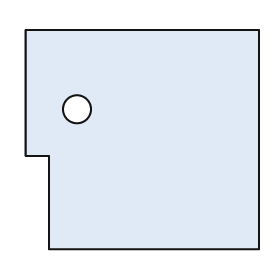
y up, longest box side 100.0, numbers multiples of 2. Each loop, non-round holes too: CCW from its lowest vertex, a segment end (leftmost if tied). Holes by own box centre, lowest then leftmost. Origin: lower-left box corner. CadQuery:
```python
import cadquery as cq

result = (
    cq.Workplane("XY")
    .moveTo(10.0, 0.0)
    .lineTo(100.0, 0.0)
    .lineTo(100.0, 94.0)
    .lineTo(0.0, 94.0)
    .lineTo(0.0, 40.0)
    .lineTo(10.0, 40.0)
    .close()
    .moveTo(22.0, 60.0)
    .circle(6.0)
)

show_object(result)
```